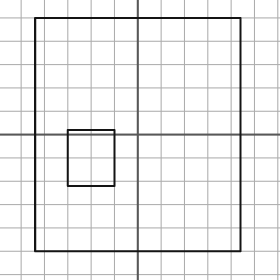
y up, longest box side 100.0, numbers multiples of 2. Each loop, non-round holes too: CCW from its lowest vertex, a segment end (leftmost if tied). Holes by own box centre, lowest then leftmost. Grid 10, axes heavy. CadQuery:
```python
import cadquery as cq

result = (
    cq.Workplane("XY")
    .moveTo(-44.0, -50.0)
    .lineTo(44.0, -50.0)
    .lineTo(44.0, 50.0)
    .lineTo(-44.0, 50.0)
    .close()
    .moveTo(-30.0, -22.0)
    .lineTo(-10.0, -22.0)
    .lineTo(-10.0, 2.0)
    .lineTo(-30.0, 2.0)
    .close()
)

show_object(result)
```